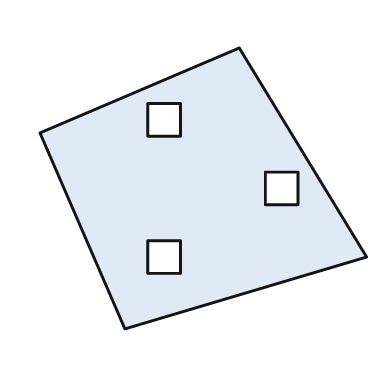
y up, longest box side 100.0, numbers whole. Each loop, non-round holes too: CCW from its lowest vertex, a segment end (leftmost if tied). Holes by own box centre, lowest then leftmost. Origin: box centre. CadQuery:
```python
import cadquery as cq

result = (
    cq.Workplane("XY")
    .moveTo(-24.0, -43.0)
    .lineTo(50.0, -21.0)
    .lineTo(11.0, 43.0)
    .lineTo(-50.0, 17.0)
    .close()
    .moveTo(-17.0, -26.0)
    .lineTo(-7.0, -26.0)
    .lineTo(-7.0, -16.0)
    .lineTo(-17.0, -16.0)
    .close()
    .moveTo(19.0, -5.0)
    .lineTo(29.0, -5.0)
    .lineTo(29.0, 5.0)
    .lineTo(19.0, 5.0)
    .close()
    .moveTo(-17.0, 16.0)
    .lineTo(-7.0, 16.0)
    .lineTo(-7.0, 26.0)
    .lineTo(-17.0, 26.0)
    .close()
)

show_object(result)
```